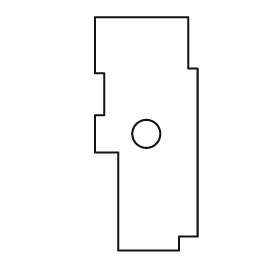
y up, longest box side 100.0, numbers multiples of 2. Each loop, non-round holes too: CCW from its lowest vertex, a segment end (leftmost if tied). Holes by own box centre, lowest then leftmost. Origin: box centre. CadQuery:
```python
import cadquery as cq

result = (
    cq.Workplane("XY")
    .moveTo(-12.0, -50.0)
    .lineTo(14.0, -50.0)
    .lineTo(14.0, -44.0)
    .lineTo(22.0, -44.0)
    .lineTo(22.0, 28.0)
    .lineTo(18.0, 28.0)
    .lineTo(18.0, 50.0)
    .lineTo(-22.0, 50.0)
    .lineTo(-22.0, 26.0)
    .lineTo(-18.0, 26.0)
    .lineTo(-18.0, 8.0)
    .lineTo(-22.0, 8.0)
    .lineTo(-22.0, -8.0)
    .lineTo(-12.0, -8.0)
    .close()
    .moveTo(0.0, 0.0)
    .circle(6.0)
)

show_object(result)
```